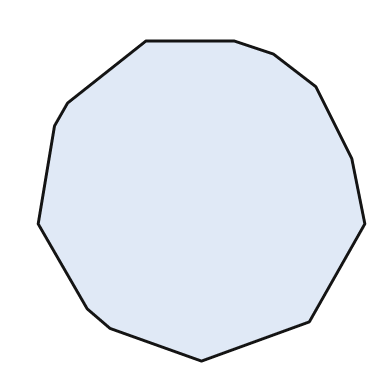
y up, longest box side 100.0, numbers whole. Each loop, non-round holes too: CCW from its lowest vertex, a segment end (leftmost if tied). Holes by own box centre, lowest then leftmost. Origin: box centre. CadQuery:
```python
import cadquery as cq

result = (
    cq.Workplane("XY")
    .moveTo(0.0, -49.0)
    .lineTo(33.0, -37.0)
    .lineTo(50.0, -7.0)
    .lineTo(46.0, 13.0)
    .lineTo(35.0, 35.0)
    .lineTo(22.0, 45.0)
    .lineTo(10.0, 49.0)
    .lineTo(-17.0, 49.0)
    .lineTo(-41.0, 30.0)
    .lineTo(-45.0, 23.0)
    .lineTo(-50.0, -7.0)
    .lineTo(-35.0, -33.0)
    .lineTo(-28.0, -39.0)
    .close()
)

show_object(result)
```